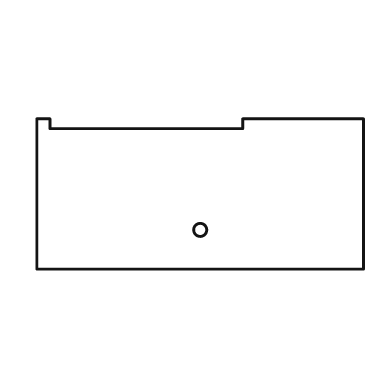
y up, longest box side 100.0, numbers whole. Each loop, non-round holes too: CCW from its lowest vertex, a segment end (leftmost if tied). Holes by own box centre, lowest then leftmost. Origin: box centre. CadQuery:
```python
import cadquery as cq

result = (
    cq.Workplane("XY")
    .moveTo(-50.0, -23.0)
    .lineTo(50.0, -23.0)
    .lineTo(50.0, 23.0)
    .lineTo(13.0, 23.0)
    .lineTo(13.0, 20.0)
    .lineTo(-46.0, 20.0)
    .lineTo(-46.0, 23.0)
    .lineTo(-50.0, 23.0)
    .close()
    .moveTo(0.0, -11.0)
    .circle(2.0)
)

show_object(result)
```